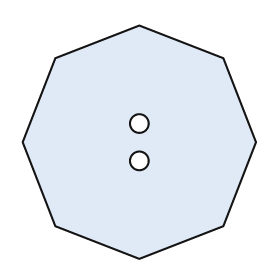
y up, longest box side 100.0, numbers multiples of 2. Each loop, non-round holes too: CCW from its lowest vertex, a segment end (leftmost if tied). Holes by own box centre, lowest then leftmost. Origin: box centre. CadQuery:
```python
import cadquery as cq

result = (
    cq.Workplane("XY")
    .moveTo(0.0, -50.0)
    .lineTo(36.0, -36.0)
    .lineTo(50.0, 0.0)
    .lineTo(36.0, 36.0)
    .lineTo(0.0, 50.0)
    .lineTo(-36.0, 36.0)
    .lineTo(-50.0, 0.0)
    .lineTo(-36.0, -36.0)
    .close()
    .moveTo(0.0, -8.0)
    .circle(4.0)
    .moveTo(0.0, 8.0)
    .circle(4.0)
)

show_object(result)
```